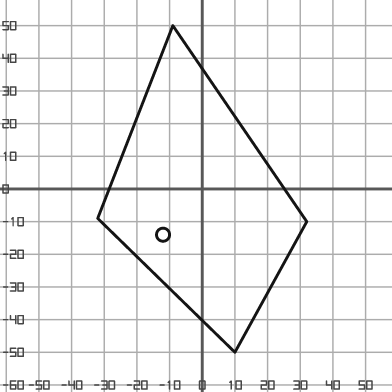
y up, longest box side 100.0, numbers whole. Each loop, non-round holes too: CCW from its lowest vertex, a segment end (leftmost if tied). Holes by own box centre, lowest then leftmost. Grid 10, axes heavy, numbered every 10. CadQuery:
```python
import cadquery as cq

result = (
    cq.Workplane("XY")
    .moveTo(10.0, -50.0)
    .lineTo(32.0, -10.0)
    .lineTo(-9.0, 50.0)
    .lineTo(-32.0, -9.0)
    .close()
    .moveTo(-12.0, -14.0)
    .circle(2.0)
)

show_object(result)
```